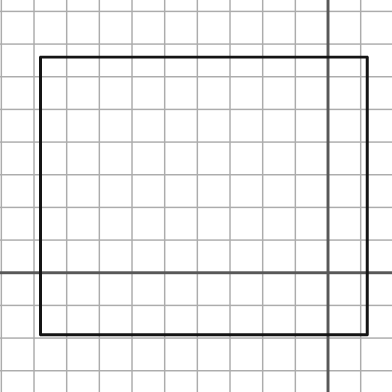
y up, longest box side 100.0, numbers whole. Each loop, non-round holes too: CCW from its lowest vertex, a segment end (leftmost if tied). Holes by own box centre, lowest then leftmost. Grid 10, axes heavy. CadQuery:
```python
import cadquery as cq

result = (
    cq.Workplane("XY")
    .moveTo(-88.0, -19.0)
    .lineTo(12.0, -19.0)
    .lineTo(12.0, 66.0)
    .lineTo(-88.0, 66.0)
    .close()
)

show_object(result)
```